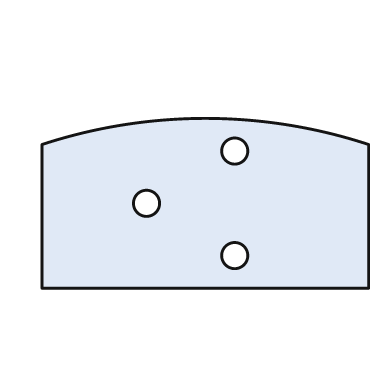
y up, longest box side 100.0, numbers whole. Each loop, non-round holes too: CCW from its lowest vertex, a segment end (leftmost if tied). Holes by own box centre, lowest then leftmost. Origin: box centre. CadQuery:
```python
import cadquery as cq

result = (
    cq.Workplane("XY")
    .moveTo(-50.0, -26.0)
    .lineTo(50.0, -26.0)
    .lineTo(50.0, 18.0)
    .threePointArc((0.0, 26.0), (-50.0, 18.0))
    .close()
    .moveTo(9.0, -16.0)
    .circle(4.0)
    .moveTo(-18.0, 0.0)
    .circle(4.0)
    .moveTo(9.0, 16.0)
    .circle(4.0)
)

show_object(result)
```